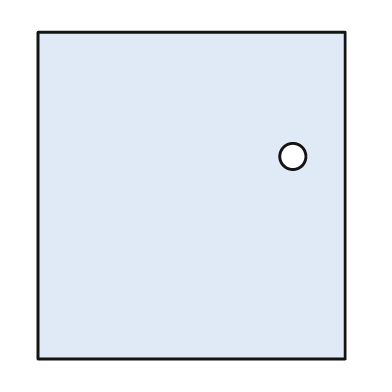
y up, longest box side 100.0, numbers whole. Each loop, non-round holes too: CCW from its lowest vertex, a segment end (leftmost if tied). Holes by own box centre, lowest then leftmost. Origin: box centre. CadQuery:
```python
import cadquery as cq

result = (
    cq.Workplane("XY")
    .moveTo(-47.0, -50.0)
    .lineTo(47.0, -50.0)
    .lineTo(47.0, 50.0)
    .lineTo(-47.0, 50.0)
    .close()
    .moveTo(31.0, 12.0)
    .circle(4.0)
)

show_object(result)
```